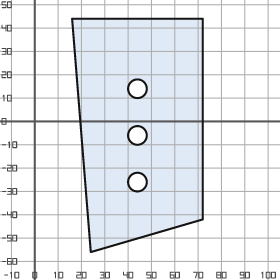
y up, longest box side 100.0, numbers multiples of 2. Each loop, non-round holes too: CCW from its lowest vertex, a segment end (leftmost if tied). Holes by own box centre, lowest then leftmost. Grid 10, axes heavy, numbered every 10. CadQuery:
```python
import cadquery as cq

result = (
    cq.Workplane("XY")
    .moveTo(24.0, -56.0)
    .lineTo(72.0, -42.0)
    .lineTo(72.0, 44.0)
    .lineTo(16.0, 44.0)
    .close()
    .moveTo(44.0, -26.0)
    .circle(4.0)
    .moveTo(44.0, -6.0)
    .circle(4.0)
    .moveTo(44.0, 14.0)
    .circle(4.0)
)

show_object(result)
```